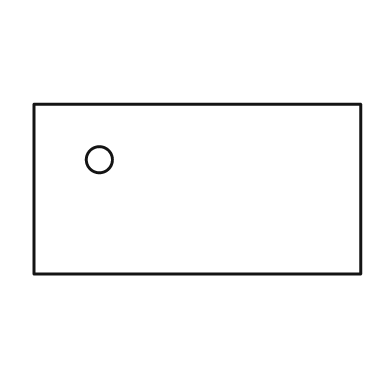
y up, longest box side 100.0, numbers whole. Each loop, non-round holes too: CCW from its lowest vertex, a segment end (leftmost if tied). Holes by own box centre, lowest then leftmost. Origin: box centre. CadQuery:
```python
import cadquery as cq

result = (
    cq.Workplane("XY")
    .moveTo(-50.0, -26.0)
    .lineTo(50.0, -26.0)
    .lineTo(50.0, 26.0)
    .lineTo(-50.0, 26.0)
    .close()
    .moveTo(-30.0, 9.0)
    .circle(4.0)
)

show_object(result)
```